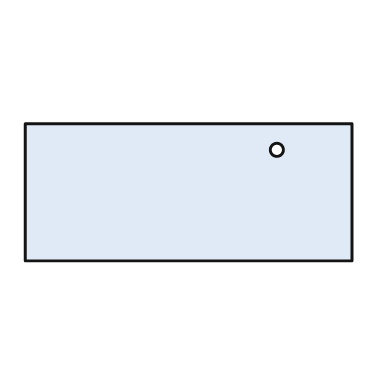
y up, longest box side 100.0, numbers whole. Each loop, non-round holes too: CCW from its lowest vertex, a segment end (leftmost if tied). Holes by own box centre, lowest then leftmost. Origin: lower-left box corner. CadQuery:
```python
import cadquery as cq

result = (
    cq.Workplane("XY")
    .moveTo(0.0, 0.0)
    .lineTo(100.0, 0.0)
    .lineTo(100.0, 42.0)
    .lineTo(0.0, 42.0)
    .close()
    .moveTo(77.0, 34.0)
    .circle(2.0)
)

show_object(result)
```